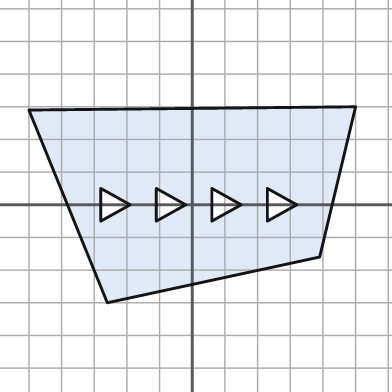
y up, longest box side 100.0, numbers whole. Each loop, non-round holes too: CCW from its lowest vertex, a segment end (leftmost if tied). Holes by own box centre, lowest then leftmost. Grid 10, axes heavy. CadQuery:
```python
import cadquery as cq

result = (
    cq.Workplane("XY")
    .moveTo(-26.0, -30.0)
    .lineTo(39.0, -16.0)
    .lineTo(50.0, 30.0)
    .lineTo(-50.0, 29.0)
    .close()
    .moveTo(-28.0, -5.0)
    .lineTo(-19.0, 0.0)
    .lineTo(-28.0, 5.0)
    .close()
    .moveTo(-11.0, -5.0)
    .lineTo(-2.0, 0.0)
    .lineTo(-11.0, 5.0)
    .close()
    .moveTo(6.0, -5.0)
    .lineTo(15.0, 0.0)
    .lineTo(6.0, 5.0)
    .close()
    .moveTo(23.0, -5.0)
    .lineTo(32.0, 0.0)
    .lineTo(23.0, 5.0)
    .close()
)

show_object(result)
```